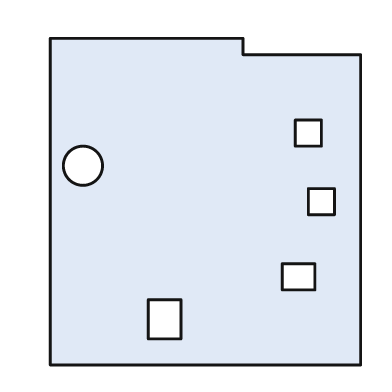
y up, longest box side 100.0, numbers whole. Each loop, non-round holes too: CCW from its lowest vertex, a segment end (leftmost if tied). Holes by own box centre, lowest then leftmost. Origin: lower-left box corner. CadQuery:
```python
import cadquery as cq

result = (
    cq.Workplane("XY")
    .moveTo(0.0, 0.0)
    .lineTo(95.0, 0.0)
    .lineTo(95.0, 95.0)
    .lineTo(59.0, 95.0)
    .lineTo(59.0, 100.0)
    .lineTo(0.0, 100.0)
    .close()
    .moveTo(30.0, 8.0)
    .lineTo(40.0, 8.0)
    .lineTo(40.0, 20.0)
    .lineTo(30.0, 20.0)
    .close()
    .moveTo(71.0, 23.0)
    .lineTo(81.0, 23.0)
    .lineTo(81.0, 31.0)
    .lineTo(71.0, 31.0)
    .close()
    .moveTo(79.0, 46.0)
    .lineTo(87.0, 46.0)
    .lineTo(87.0, 54.0)
    .lineTo(79.0, 54.0)
    .close()
    .moveTo(10.0, 61.0)
    .circle(6.0)
    .moveTo(75.0, 67.0)
    .lineTo(83.0, 67.0)
    .lineTo(83.0, 75.0)
    .lineTo(75.0, 75.0)
    .close()
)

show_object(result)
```